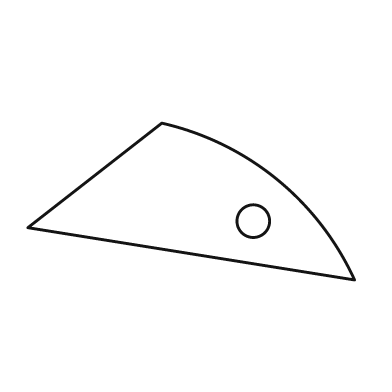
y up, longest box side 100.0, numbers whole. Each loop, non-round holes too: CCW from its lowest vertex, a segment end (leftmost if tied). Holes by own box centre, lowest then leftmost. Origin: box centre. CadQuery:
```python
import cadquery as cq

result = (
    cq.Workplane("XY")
    .moveTo(50.0, -24.0)
    .threePointArc((26.0, 7.0), (-9.0, 24.0))
    .lineTo(-50.0, -8.0)
    .close()
    .moveTo(19.0, -6.0)
    .circle(5.0)
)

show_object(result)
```